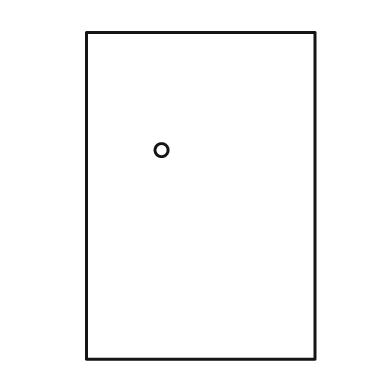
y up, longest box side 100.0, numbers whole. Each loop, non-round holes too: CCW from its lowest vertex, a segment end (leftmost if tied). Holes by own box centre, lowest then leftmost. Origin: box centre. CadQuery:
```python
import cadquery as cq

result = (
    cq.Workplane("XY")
    .moveTo(-35.0, -50.0)
    .lineTo(35.0, -50.0)
    .lineTo(35.0, 50.0)
    .lineTo(-35.0, 50.0)
    .close()
    .moveTo(-12.0, 14.0)
    .circle(2.0)
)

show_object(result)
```